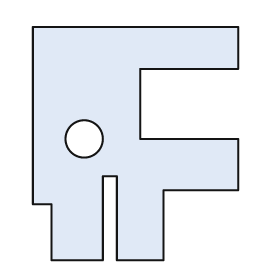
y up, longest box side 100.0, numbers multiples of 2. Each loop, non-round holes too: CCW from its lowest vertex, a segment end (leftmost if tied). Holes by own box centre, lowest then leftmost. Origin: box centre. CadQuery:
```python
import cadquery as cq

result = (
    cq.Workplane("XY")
    .moveTo(-36.0, -50.0)
    .lineTo(-14.0, -50.0)
    .lineTo(-14.0, -14.0)
    .lineTo(-8.0, -14.0)
    .lineTo(-8.0, -50.0)
    .lineTo(12.0, -50.0)
    .lineTo(12.0, -20.0)
    .lineTo(44.0, -20.0)
    .lineTo(44.0, 2.0)
    .lineTo(2.0, 2.0)
    .lineTo(2.0, 32.0)
    .lineTo(44.0, 32.0)
    .lineTo(44.0, 50.0)
    .lineTo(-44.0, 50.0)
    .lineTo(-44.0, -26.0)
    .lineTo(-36.0, -26.0)
    .close()
    .moveTo(-22.0, 2.0)
    .circle(8.0)
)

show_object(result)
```